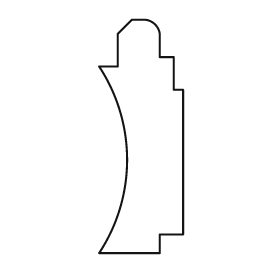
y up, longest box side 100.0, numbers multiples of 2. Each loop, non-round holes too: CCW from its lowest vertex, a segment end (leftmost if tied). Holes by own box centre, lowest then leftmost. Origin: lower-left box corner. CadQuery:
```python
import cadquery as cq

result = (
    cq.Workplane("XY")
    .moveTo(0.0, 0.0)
    .lineTo(26.0, 0.0)
    .lineTo(26.0, 8.0)
    .lineTo(36.0, 8.0)
    .lineTo(36.0, 70.0)
    .lineTo(32.0, 70.0)
    .lineTo(32.0, 84.0)
    .lineTo(26.0, 84.0)
    .lineTo(26.0, 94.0)
    .threePointArc((24.0, 98.0), (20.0, 100.0))
    .lineTo(14.0, 100.0)
    .lineTo(8.0, 94.0)
    .lineTo(8.0, 80.0)
    .lineTo(0.0, 80.0)
    .threePointArc((12.0, 40.0), (0.0, 0.0))
    .close()
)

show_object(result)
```